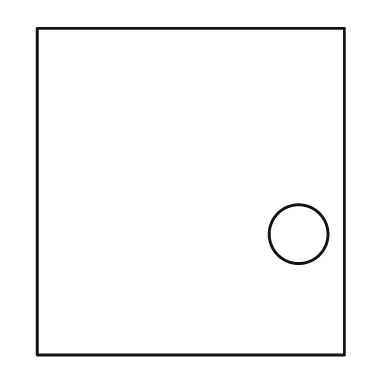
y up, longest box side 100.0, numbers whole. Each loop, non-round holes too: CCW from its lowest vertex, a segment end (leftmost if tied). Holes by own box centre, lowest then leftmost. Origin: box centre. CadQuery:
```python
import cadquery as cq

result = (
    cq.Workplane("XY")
    .moveTo(-47.0, -50.0)
    .lineTo(47.0, -50.0)
    .lineTo(47.0, 50.0)
    .lineTo(-47.0, 50.0)
    .close()
    .moveTo(33.0, -13.0)
    .circle(9.0)
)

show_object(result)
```